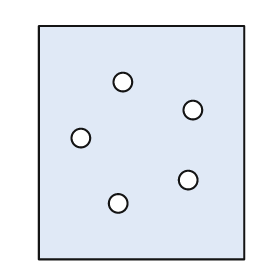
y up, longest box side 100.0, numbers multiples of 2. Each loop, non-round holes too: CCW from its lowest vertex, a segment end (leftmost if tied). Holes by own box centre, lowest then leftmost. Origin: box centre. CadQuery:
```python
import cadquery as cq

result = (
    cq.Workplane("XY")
    .moveTo(-44.0, -50.0)
    .lineTo(44.0, -50.0)
    .lineTo(44.0, 50.0)
    .lineTo(-44.0, 50.0)
    .close()
    .moveTo(-10.0, -26.0)
    .circle(4.0)
    .moveTo(20.0, -16.0)
    .circle(4.0)
    .moveTo(-26.0, 2.0)
    .circle(4.0)
    .moveTo(22.0, 14.0)
    .circle(4.0)
    .moveTo(-8.0, 26.0)
    .circle(4.0)
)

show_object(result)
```